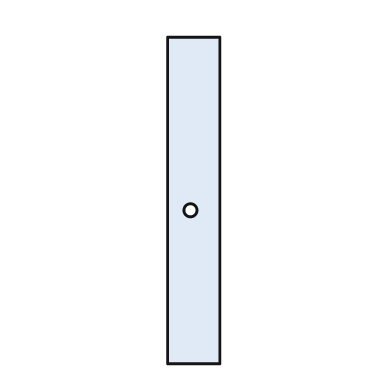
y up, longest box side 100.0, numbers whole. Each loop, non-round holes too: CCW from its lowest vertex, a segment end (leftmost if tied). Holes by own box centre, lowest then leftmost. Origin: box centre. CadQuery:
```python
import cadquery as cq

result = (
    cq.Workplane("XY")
    .moveTo(-8.0, -50.0)
    .lineTo(8.0, -50.0)
    .lineTo(8.0, 50.0)
    .lineTo(-8.0, 50.0)
    .close()
    .moveTo(-1.0, -3.0)
    .circle(2.0)
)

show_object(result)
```